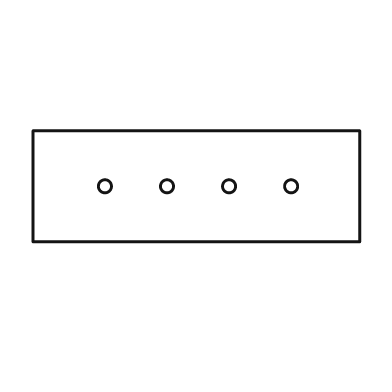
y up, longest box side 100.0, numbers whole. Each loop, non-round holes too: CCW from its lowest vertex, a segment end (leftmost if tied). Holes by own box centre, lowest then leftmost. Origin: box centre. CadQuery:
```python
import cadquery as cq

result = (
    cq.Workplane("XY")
    .moveTo(-50.0, -17.0)
    .lineTo(50.0, -17.0)
    .lineTo(50.0, 17.0)
    .lineTo(-50.0, 17.0)
    .close()
    .moveTo(-28.0, 0.0)
    .circle(2.0)
    .moveTo(-9.0, 0.0)
    .circle(2.0)
    .moveTo(10.0, 0.0)
    .circle(2.0)
    .moveTo(29.0, 0.0)
    .circle(2.0)
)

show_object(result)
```